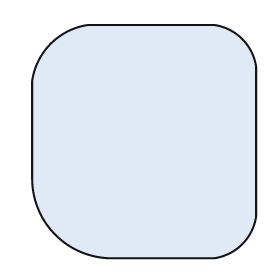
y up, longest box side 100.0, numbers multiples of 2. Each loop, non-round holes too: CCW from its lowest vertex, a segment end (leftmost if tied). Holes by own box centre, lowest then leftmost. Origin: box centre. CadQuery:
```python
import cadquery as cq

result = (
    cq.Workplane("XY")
    .moveTo(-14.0, -50.0)
    .lineTo(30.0, -50.0)
    .threePointArc((42.0, -44.0), (48.0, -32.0))
    .lineTo(48.0, 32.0)
    .threePointArc((42.0, 44.0), (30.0, 50.0))
    .lineTo(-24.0, 50.0)
    .threePointArc((-40.0, 42.0), (-48.0, 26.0))
    .lineTo(-48.0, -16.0)
    .threePointArc((-38.0, -40.0), (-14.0, -50.0))
    .close()
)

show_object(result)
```